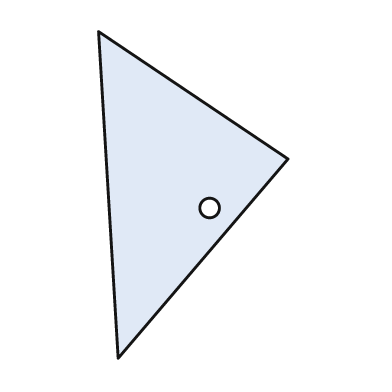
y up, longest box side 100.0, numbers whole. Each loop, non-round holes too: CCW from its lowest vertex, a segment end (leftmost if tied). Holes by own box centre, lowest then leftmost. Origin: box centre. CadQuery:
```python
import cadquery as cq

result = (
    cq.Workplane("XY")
    .moveTo(-23.0, -50.0)
    .lineTo(29.0, 11.0)
    .lineTo(-29.0, 50.0)
    .close()
    .moveTo(5.0, -4.0)
    .circle(3.0)
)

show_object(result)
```